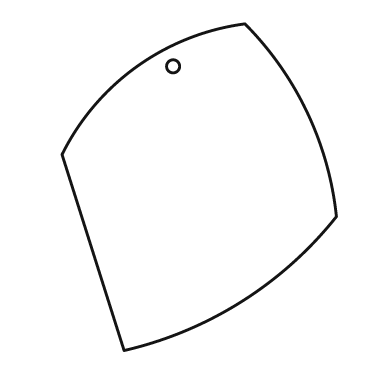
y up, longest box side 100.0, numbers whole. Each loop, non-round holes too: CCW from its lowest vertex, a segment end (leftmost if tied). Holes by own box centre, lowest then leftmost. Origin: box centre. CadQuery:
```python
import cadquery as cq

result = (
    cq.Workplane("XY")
    .moveTo(-23.0, -50.0)
    .threePointArc((13.0, -35.0), (42.0, -9.0))
    .threePointArc((33.0, 23.0), (14.0, 50.0))
    .threePointArc((-19.0, 37.0), (-42.0, 10.0))
    .close()
    .moveTo(-8.0, 37.0)
    .circle(2.0)
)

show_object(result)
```